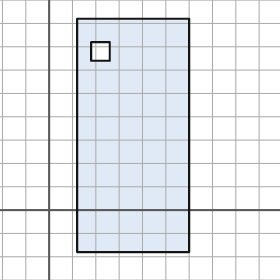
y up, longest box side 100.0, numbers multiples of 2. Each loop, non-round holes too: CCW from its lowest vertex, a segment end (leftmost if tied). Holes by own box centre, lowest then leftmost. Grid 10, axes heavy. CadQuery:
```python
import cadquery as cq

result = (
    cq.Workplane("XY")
    .moveTo(12.0, -18.0)
    .lineTo(60.0, -18.0)
    .lineTo(60.0, 82.0)
    .lineTo(12.0, 82.0)
    .close()
    .moveTo(18.0, 64.0)
    .lineTo(26.0, 64.0)
    .lineTo(26.0, 72.0)
    .lineTo(18.0, 72.0)
    .close()
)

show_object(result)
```